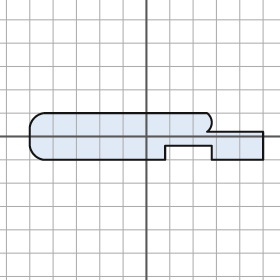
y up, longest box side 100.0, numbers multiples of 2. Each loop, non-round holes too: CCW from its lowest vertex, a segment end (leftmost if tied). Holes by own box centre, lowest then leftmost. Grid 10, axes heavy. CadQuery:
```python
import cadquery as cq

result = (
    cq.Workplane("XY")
    .moveTo(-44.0, -10.0)
    .lineTo(8.0, -10.0)
    .lineTo(8.0, -4.0)
    .lineTo(28.0, -4.0)
    .lineTo(28.0, -10.0)
    .lineTo(50.0, -10.0)
    .lineTo(50.0, 2.0)
    .lineTo(26.0, 2.0)
    .threePointArc((28.0, 6.0), (26.0, 10.0))
    .lineTo(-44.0, 10.0)
    .threePointArc((-48.0, 8.0), (-50.0, 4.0))
    .lineTo(-50.0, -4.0)
    .threePointArc((-48.0, -8.0), (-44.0, -10.0))
    .close()
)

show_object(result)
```